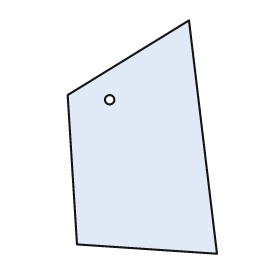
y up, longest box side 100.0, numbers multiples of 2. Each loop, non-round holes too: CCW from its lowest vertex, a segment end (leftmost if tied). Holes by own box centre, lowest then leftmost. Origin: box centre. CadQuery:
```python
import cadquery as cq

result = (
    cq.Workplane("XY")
    .moveTo(32.0, -50.0)
    .lineTo(20.0, 50.0)
    .lineTo(-32.0, 18.0)
    .lineTo(-28.0, -46.0)
    .close()
    .moveTo(-14.0, 16.0)
    .circle(2.0)
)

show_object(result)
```